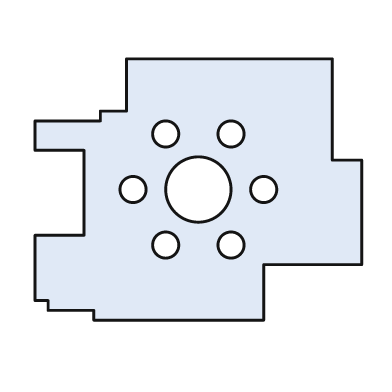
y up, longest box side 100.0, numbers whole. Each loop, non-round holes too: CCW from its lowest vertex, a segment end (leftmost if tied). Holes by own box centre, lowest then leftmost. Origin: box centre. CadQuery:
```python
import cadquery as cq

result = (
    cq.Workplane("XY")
    .moveTo(-32.0, -40.0)
    .lineTo(20.0, -40.0)
    .lineTo(20.0, -23.0)
    .lineTo(50.0, -23.0)
    .lineTo(50.0, 9.0)
    .lineTo(41.0, 9.0)
    .lineTo(41.0, 40.0)
    .lineTo(-22.0, 40.0)
    .lineTo(-22.0, 24.0)
    .lineTo(-30.0, 24.0)
    .lineTo(-30.0, 21.0)
    .lineTo(-50.0, 21.0)
    .lineTo(-50.0, 12.0)
    .lineTo(-35.0, 12.0)
    .lineTo(-35.0, -14.0)
    .lineTo(-50.0, -14.0)
    .lineTo(-50.0, -34.0)
    .lineTo(-46.0, -34.0)
    .lineTo(-46.0, -37.0)
    .lineTo(-32.0, -37.0)
    .close()
    .moveTo(-10.0, -17.0)
    .circle(4.0)
    .moveTo(10.0, -17.0)
    .circle(4.0)
    .moveTo(-20.0, 0.0)
    .circle(4.0)
    .moveTo(0.0, 0.0)
    .circle(10.0)
    .moveTo(20.0, 0.0)
    .circle(4.0)
    .moveTo(-10.0, 17.0)
    .circle(4.0)
    .moveTo(10.0, 17.0)
    .circle(4.0)
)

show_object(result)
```